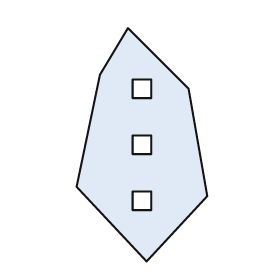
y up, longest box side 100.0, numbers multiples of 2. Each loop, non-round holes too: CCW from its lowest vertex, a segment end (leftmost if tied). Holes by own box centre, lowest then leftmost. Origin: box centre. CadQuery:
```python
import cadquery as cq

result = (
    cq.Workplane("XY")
    .moveTo(2.0, -50.0)
    .lineTo(28.0, -22.0)
    .lineTo(20.0, 24.0)
    .lineTo(-6.0, 50.0)
    .lineTo(-18.0, 30.0)
    .lineTo(-28.0, -18.0)
    .close()
    .moveTo(-4.0, -28.0)
    .lineTo(4.0, -28.0)
    .lineTo(4.0, -20.0)
    .lineTo(-4.0, -20.0)
    .close()
    .moveTo(-4.0, -4.0)
    .lineTo(4.0, -4.0)
    .lineTo(4.0, 4.0)
    .lineTo(-4.0, 4.0)
    .close()
    .moveTo(-4.0, 20.0)
    .lineTo(4.0, 20.0)
    .lineTo(4.0, 28.0)
    .lineTo(-4.0, 28.0)
    .close()
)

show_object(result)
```